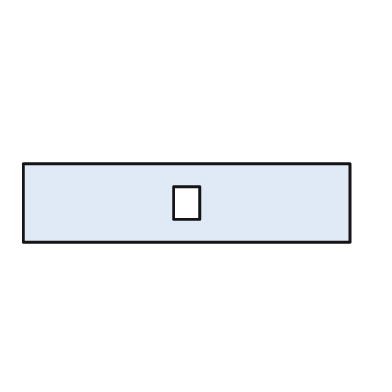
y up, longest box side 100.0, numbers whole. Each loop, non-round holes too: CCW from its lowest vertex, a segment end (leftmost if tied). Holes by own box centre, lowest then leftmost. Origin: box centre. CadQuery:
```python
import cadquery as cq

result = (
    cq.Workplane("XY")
    .moveTo(-50.0, -12.0)
    .lineTo(50.0, -12.0)
    .lineTo(50.0, 12.0)
    .lineTo(-50.0, 12.0)
    .close()
    .moveTo(-4.0, -5.0)
    .lineTo(4.0, -5.0)
    .lineTo(4.0, 5.0)
    .lineTo(-4.0, 5.0)
    .close()
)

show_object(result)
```